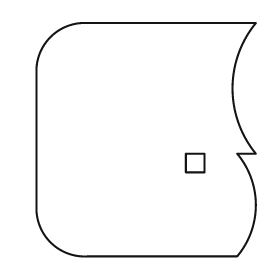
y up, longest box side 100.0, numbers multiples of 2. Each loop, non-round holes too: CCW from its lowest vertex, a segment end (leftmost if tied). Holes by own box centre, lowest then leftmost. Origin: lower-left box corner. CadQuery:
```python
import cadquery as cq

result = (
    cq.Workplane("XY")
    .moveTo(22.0, 0.0)
    .lineTo(86.0, 0.0)
    .threePointArc((94.0, 22.0), (86.0, 44.0))
    .lineTo(94.0, 44.0)
    .threePointArc((84.0, 72.0), (94.0, 100.0))
    .lineTo(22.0, 100.0)
    .threePointArc((6.0, 94.0), (0.0, 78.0))
    .lineTo(0.0, 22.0)
    .threePointArc((6.0, 6.0), (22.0, 0.0))
    .close()
    .moveTo(64.0, 36.0)
    .lineTo(72.0, 36.0)
    .lineTo(72.0, 44.0)
    .lineTo(64.0, 44.0)
    .close()
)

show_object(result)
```